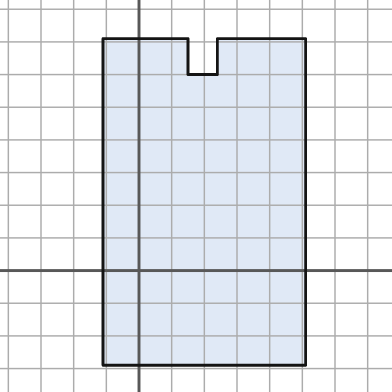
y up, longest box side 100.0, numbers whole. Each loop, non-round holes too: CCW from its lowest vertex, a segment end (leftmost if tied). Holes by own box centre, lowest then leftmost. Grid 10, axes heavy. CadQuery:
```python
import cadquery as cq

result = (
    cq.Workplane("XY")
    .moveTo(-11.0, -29.0)
    .lineTo(51.0, -29.0)
    .lineTo(51.0, 71.0)
    .lineTo(24.0, 71.0)
    .lineTo(24.0, 60.0)
    .lineTo(15.0, 60.0)
    .lineTo(15.0, 71.0)
    .lineTo(-11.0, 71.0)
    .close()
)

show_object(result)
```